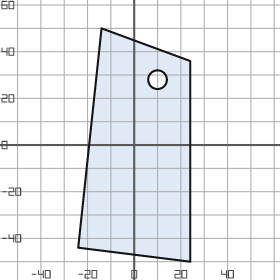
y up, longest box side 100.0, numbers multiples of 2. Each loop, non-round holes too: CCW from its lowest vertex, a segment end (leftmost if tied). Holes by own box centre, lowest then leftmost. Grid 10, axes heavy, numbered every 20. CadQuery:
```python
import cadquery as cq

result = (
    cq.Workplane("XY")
    .moveTo(24.0, -50.0)
    .lineTo(24.0, 36.0)
    .lineTo(-14.0, 50.0)
    .lineTo(-24.0, -44.0)
    .close()
    .moveTo(10.0, 28.0)
    .circle(4.0)
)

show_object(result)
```